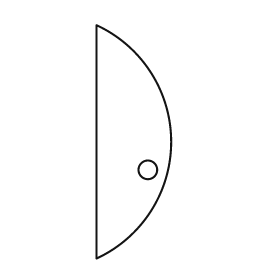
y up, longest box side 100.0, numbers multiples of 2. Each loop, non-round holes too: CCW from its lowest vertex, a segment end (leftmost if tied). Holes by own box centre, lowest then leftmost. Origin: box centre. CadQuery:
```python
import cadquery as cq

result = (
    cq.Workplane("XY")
    .moveTo(-16.0, -50.0)
    .threePointArc((16.0, 0.0), (-16.0, 50.0))
    .close()
    .moveTo(6.0, -12.0)
    .circle(4.0)
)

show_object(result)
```